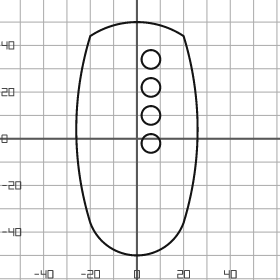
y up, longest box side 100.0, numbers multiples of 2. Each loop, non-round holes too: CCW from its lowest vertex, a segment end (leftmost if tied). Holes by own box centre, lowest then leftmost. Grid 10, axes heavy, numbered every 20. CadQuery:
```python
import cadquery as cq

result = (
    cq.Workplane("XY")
    .moveTo(-20.0, -36.0)
    .threePointArc((0.0, -50.0), (20.0, -36.0))
    .threePointArc((26.0, 4.0), (20.0, 44.0))
    .threePointArc((0.0, 50.0), (-20.0, 44.0))
    .threePointArc((-26.0, 4.0), (-20.0, -36.0))
    .close()
    .moveTo(6.0, -2.0)
    .circle(4.0)
    .moveTo(6.0, 10.0)
    .circle(4.0)
    .moveTo(6.0, 22.0)
    .circle(4.0)
    .moveTo(6.0, 34.0)
    .circle(4.0)
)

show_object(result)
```